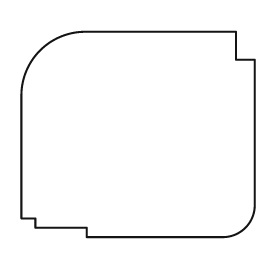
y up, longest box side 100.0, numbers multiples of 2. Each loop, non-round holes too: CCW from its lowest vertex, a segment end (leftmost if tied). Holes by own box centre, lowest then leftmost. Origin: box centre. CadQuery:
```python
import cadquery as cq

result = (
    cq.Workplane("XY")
    .moveTo(-22.0, -44.0)
    .lineTo(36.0, -44.0)
    .threePointArc((46.0, -40.0), (50.0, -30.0))
    .lineTo(50.0, 32.0)
    .lineTo(42.0, 32.0)
    .lineTo(42.0, 44.0)
    .lineTo(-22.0, 44.0)
    .threePointArc((-42.0, 36.0), (-50.0, 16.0))
    .lineTo(-50.0, -36.0)
    .lineTo(-44.0, -36.0)
    .lineTo(-44.0, -40.0)
    .lineTo(-22.0, -40.0)
    .close()
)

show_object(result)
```